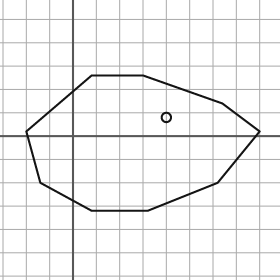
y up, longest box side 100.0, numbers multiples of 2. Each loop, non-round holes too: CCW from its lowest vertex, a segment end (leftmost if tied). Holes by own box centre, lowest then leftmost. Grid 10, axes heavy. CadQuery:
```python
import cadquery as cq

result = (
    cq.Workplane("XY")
    .moveTo(8.0, -32.0)
    .lineTo(32.0, -32.0)
    .lineTo(62.0, -20.0)
    .lineTo(80.0, 2.0)
    .lineTo(64.0, 14.0)
    .lineTo(30.0, 26.0)
    .lineTo(8.0, 26.0)
    .lineTo(-20.0, 2.0)
    .lineTo(-14.0, -20.0)
    .close()
    .moveTo(40.0, 8.0)
    .circle(2.0)
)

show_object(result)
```